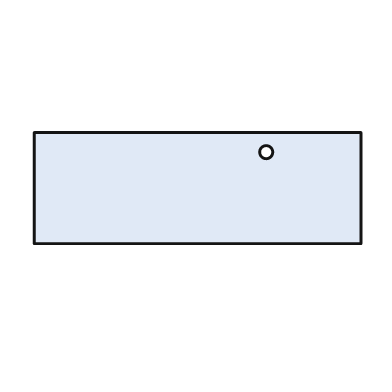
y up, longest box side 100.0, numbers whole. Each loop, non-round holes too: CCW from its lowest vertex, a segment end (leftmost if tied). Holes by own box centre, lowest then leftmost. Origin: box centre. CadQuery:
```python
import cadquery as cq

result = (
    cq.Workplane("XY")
    .moveTo(-50.0, -17.0)
    .lineTo(50.0, -17.0)
    .lineTo(50.0, 17.0)
    .lineTo(-50.0, 17.0)
    .close()
    .moveTo(21.0, 11.0)
    .circle(2.0)
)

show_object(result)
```